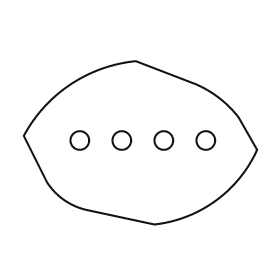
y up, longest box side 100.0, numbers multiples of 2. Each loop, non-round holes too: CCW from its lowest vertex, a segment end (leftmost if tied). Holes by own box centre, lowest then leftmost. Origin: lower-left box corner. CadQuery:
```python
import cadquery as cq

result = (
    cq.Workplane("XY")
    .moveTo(56.0, 0.0)
    .threePointArc((82.0, 10.0), (100.0, 32.0))
    .lineTo(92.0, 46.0)
    .threePointArc((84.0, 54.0), (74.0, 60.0))
    .lineTo(48.0, 70.0)
    .threePointArc((20.0, 60.0), (0.0, 38.0))
    .lineTo(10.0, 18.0)
    .threePointArc((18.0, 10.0), (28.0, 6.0))
    .close()
    .moveTo(24.0, 36.0)
    .circle(4.0)
    .moveTo(42.0, 36.0)
    .circle(4.0)
    .moveTo(60.0, 36.0)
    .circle(4.0)
    .moveTo(78.0, 36.0)
    .circle(4.0)
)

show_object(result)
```